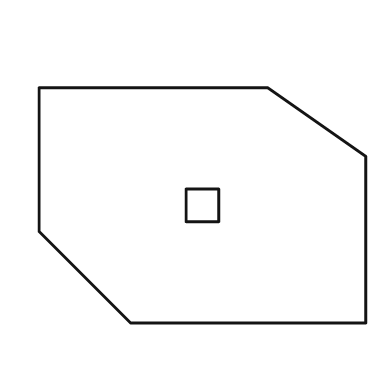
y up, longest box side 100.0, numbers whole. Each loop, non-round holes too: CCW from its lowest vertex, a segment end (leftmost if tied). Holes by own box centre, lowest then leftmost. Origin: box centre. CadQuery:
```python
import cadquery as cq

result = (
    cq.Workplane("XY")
    .moveTo(-22.0, -36.0)
    .lineTo(50.0, -36.0)
    .lineTo(50.0, 15.0)
    .lineTo(20.0, 36.0)
    .lineTo(-50.0, 36.0)
    .lineTo(-50.0, -8.0)
    .close()
    .moveTo(-5.0, -5.0)
    .lineTo(5.0, -5.0)
    .lineTo(5.0, 5.0)
    .lineTo(-5.0, 5.0)
    .close()
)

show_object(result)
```